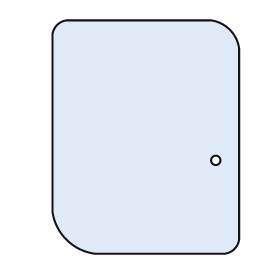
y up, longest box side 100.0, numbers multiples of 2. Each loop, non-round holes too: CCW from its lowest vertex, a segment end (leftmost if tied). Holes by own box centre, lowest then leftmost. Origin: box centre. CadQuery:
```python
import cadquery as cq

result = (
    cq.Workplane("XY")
    .moveTo(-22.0, -50.0)
    .lineTo(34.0, -50.0)
    .threePointArc((38.0, -48.0), (40.0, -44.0))
    .lineTo(40.0, 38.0)
    .threePointArc((36.0, 46.0), (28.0, 50.0))
    .lineTo(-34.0, 50.0)
    .threePointArc((-38.0, 48.0), (-40.0, 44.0))
    .lineTo(-40.0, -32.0)
    .threePointArc((-34.0, -44.0), (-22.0, -50.0))
    .close()
    .moveTo(30.0, -10.0)
    .circle(2.0)
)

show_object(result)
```